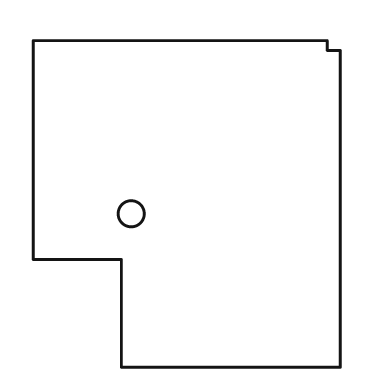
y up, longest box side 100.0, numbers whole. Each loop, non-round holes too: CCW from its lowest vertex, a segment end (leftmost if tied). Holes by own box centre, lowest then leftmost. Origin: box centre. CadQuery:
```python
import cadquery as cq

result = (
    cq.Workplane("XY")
    .moveTo(-20.0, -50.0)
    .lineTo(47.0, -50.0)
    .lineTo(47.0, 47.0)
    .lineTo(43.0, 47.0)
    .lineTo(43.0, 50.0)
    .lineTo(-47.0, 50.0)
    .lineTo(-47.0, -17.0)
    .lineTo(-20.0, -17.0)
    .close()
    .moveTo(-17.0, -3.0)
    .circle(4.0)
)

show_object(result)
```